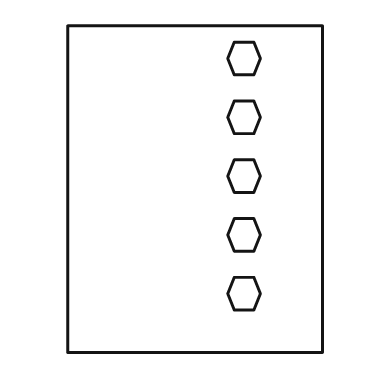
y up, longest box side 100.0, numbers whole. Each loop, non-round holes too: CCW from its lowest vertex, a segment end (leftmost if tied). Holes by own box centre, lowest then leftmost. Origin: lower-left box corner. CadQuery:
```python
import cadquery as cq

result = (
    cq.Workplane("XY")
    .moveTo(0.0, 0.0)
    .lineTo(78.0, 0.0)
    .lineTo(78.0, 100.0)
    .lineTo(0.0, 100.0)
    .close()
    .moveTo(51.0, 13.0)
    .lineTo(57.0, 13.0)
    .lineTo(59.0, 18.0)
    .lineTo(57.0, 23.0)
    .lineTo(51.0, 23.0)
    .lineTo(49.0, 18.0)
    .close()
    .moveTo(51.0, 31.0)
    .lineTo(57.0, 31.0)
    .lineTo(59.0, 36.0)
    .lineTo(57.0, 41.0)
    .lineTo(51.0, 41.0)
    .lineTo(49.0, 36.0)
    .close()
    .moveTo(51.0, 49.0)
    .lineTo(57.0, 49.0)
    .lineTo(59.0, 54.0)
    .lineTo(57.0, 59.0)
    .lineTo(51.0, 59.0)
    .lineTo(49.0, 54.0)
    .close()
    .moveTo(51.0, 67.0)
    .lineTo(57.0, 67.0)
    .lineTo(59.0, 72.0)
    .lineTo(57.0, 77.0)
    .lineTo(51.0, 77.0)
    .lineTo(49.0, 72.0)
    .close()
    .moveTo(51.0, 85.0)
    .lineTo(57.0, 85.0)
    .lineTo(59.0, 90.0)
    .lineTo(57.0, 95.0)
    .lineTo(51.0, 95.0)
    .lineTo(49.0, 90.0)
    .close()
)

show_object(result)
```